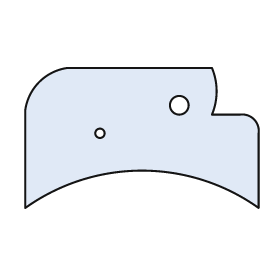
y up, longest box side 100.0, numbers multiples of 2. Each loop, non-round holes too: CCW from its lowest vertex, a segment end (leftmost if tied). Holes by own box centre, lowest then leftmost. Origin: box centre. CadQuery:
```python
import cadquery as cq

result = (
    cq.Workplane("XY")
    .moveTo(-50.0, -30.0)
    .threePointArc((0.0, -14.0), (50.0, -30.0))
    .lineTo(50.0, 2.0)
    .threePointArc((48.0, 8.0), (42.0, 10.0))
    .lineTo(30.0, 10.0)
    .threePointArc((32.0, 20.0), (30.0, 30.0))
    .lineTo(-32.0, 30.0)
    .threePointArc((-44.0, 24.0), (-50.0, 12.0))
    .close()
    .moveTo(-18.0, 2.0)
    .circle(2.0)
    .moveTo(16.0, 14.0)
    .circle(4.0)
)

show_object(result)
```